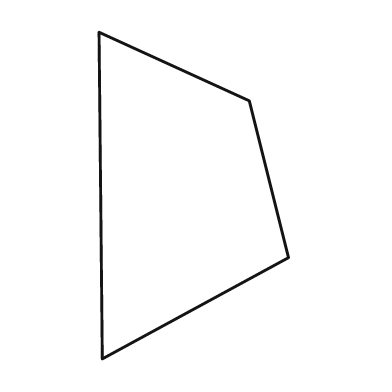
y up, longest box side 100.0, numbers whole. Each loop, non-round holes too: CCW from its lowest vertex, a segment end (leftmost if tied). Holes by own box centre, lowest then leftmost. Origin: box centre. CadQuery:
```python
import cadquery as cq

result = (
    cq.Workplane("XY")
    .moveTo(-28.0, -50.0)
    .lineTo(29.0, -19.0)
    .lineTo(17.0, 29.0)
    .lineTo(-29.0, 50.0)
    .close()
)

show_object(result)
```